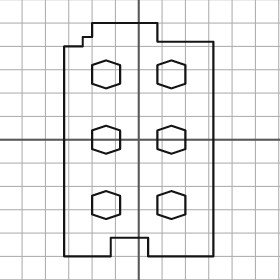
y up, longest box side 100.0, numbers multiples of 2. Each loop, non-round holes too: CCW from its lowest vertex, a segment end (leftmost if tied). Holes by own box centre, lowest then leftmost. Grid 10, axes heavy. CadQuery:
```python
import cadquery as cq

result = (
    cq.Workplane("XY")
    .moveTo(-32.0, -50.0)
    .lineTo(-12.0, -50.0)
    .lineTo(-12.0, -42.0)
    .lineTo(4.0, -42.0)
    .lineTo(4.0, -50.0)
    .lineTo(32.0, -50.0)
    .lineTo(32.0, 42.0)
    .lineTo(8.0, 42.0)
    .lineTo(8.0, 50.0)
    .lineTo(-20.0, 50.0)
    .lineTo(-20.0, 44.0)
    .lineTo(-24.0, 44.0)
    .lineTo(-24.0, 40.0)
    .lineTo(-32.0, 40.0)
    .close()
    .moveTo(-14.0, -34.0)
    .lineTo(-8.0, -32.0)
    .lineTo(-8.0, -24.0)
    .lineTo(-14.0, -22.0)
    .lineTo(-20.0, -24.0)
    .lineTo(-20.0, -32.0)
    .close()
    .moveTo(14.0, -34.0)
    .lineTo(20.0, -32.0)
    .lineTo(20.0, -24.0)
    .lineTo(14.0, -22.0)
    .lineTo(8.0, -24.0)
    .lineTo(8.0, -32.0)
    .close()
    .moveTo(-14.0, -6.0)
    .lineTo(-8.0, -4.0)
    .lineTo(-8.0, 4.0)
    .lineTo(-14.0, 6.0)
    .lineTo(-20.0, 4.0)
    .lineTo(-20.0, -4.0)
    .close()
    .moveTo(14.0, -6.0)
    .lineTo(20.0, -4.0)
    .lineTo(20.0, 4.0)
    .lineTo(14.0, 6.0)
    .lineTo(8.0, 4.0)
    .lineTo(8.0, -4.0)
    .close()
    .moveTo(-14.0, 22.0)
    .lineTo(-8.0, 24.0)
    .lineTo(-8.0, 32.0)
    .lineTo(-14.0, 34.0)
    .lineTo(-20.0, 32.0)
    .lineTo(-20.0, 24.0)
    .close()
    .moveTo(14.0, 22.0)
    .lineTo(20.0, 24.0)
    .lineTo(20.0, 32.0)
    .lineTo(14.0, 34.0)
    .lineTo(8.0, 32.0)
    .lineTo(8.0, 24.0)
    .close()
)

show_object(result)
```